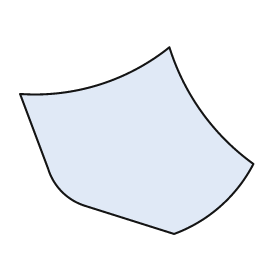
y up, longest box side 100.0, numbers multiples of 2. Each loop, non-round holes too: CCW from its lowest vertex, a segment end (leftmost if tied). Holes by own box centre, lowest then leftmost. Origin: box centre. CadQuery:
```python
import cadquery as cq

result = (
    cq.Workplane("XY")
    .moveTo(16.0, -40.0)
    .threePointArc((36.0, -28.0), (50.0, -10.0))
    .threePointArc((28.0, 12.0), (14.0, 40.0))
    .threePointArc((-16.0, 24.0), (-50.0, 20.0))
    .lineTo(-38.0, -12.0)
    .threePointArc((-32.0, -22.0), (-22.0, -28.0))
    .close()
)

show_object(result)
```